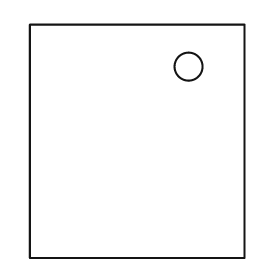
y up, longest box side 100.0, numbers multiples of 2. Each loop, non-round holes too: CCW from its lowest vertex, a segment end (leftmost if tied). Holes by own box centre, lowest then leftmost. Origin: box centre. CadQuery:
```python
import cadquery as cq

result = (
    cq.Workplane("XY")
    .moveTo(-46.0, -50.0)
    .lineTo(46.0, -50.0)
    .lineTo(46.0, 50.0)
    .lineTo(-46.0, 50.0)
    .close()
    .moveTo(22.0, 32.0)
    .circle(6.0)
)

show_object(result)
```